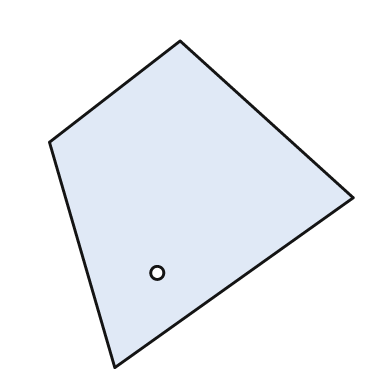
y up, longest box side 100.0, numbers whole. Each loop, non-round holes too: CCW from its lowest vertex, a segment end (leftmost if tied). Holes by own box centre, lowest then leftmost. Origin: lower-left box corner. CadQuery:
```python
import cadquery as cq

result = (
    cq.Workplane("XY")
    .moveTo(20.0, 0.0)
    .lineTo(93.0, 52.0)
    .lineTo(40.0, 100.0)
    .lineTo(0.0, 69.0)
    .close()
    .moveTo(33.0, 29.0)
    .circle(2.0)
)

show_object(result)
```